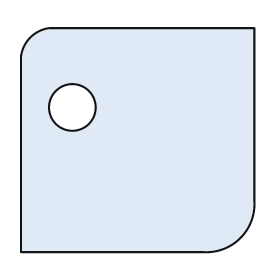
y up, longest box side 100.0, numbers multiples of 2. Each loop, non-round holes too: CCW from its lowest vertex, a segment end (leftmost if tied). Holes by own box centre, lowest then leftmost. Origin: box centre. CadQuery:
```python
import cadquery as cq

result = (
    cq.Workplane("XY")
    .moveTo(-50.0, -48.0)
    .lineTo(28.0, -48.0)
    .threePointArc((44.0, -42.0), (50.0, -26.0))
    .lineTo(50.0, 48.0)
    .lineTo(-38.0, 48.0)
    .threePointArc((-46.0, 44.0), (-50.0, 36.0))
    .close()
    .moveTo(-28.0, 14.0)
    .circle(10.0)
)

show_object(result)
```